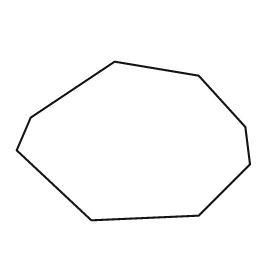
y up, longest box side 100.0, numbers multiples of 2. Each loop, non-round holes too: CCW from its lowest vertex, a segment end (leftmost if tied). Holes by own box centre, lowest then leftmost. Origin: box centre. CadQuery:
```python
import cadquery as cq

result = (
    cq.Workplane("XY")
    .moveTo(-18.0, -34.0)
    .lineTo(28.0, -32.0)
    .lineTo(50.0, -10.0)
    .lineTo(48.0, 6.0)
    .lineTo(28.0, 28.0)
    .lineTo(-8.0, 34.0)
    .lineTo(-44.0, 10.0)
    .lineTo(-50.0, -4.0)
    .close()
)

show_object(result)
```